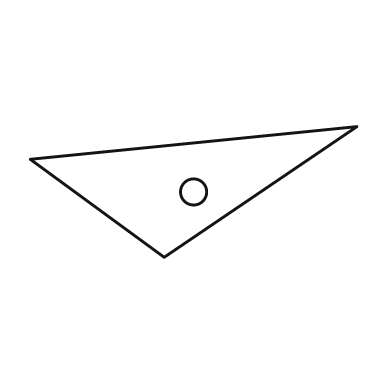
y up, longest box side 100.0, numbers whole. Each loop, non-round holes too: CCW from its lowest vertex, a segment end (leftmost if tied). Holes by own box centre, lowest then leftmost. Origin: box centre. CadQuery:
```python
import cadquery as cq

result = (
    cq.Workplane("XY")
    .moveTo(-9.0, -20.0)
    .lineTo(50.0, 20.0)
    .lineTo(-50.0, 10.0)
    .close()
    .moveTo(0.0, 0.0)
    .circle(4.0)
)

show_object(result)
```